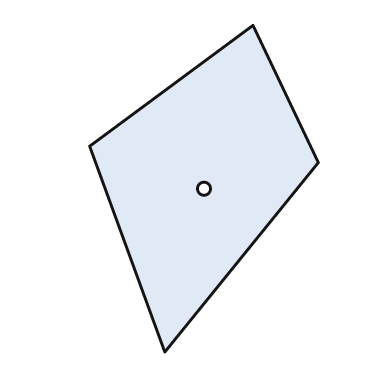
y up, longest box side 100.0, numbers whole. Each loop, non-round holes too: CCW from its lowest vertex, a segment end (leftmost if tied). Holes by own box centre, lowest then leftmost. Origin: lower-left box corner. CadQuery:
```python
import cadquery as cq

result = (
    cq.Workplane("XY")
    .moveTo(23.0, 0.0)
    .lineTo(70.0, 58.0)
    .lineTo(50.0, 100.0)
    .lineTo(0.0, 63.0)
    .close()
    .moveTo(35.0, 50.0)
    .circle(2.0)
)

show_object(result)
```